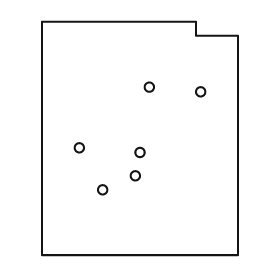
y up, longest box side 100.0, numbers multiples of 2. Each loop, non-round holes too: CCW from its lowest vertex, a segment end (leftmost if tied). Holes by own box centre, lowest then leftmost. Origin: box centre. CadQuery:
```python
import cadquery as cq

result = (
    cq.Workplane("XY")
    .moveTo(-42.0, -50.0)
    .lineTo(42.0, -50.0)
    .lineTo(42.0, 44.0)
    .lineTo(24.0, 44.0)
    .lineTo(24.0, 50.0)
    .lineTo(-42.0, 50.0)
    .close()
    .moveTo(-16.0, -22.0)
    .circle(2.0)
    .moveTo(-2.0, -16.0)
    .circle(2.0)
    .moveTo(0.0, -6.0)
    .circle(2.0)
    .moveTo(-26.0, -4.0)
    .circle(2.0)
    .moveTo(26.0, 20.0)
    .circle(2.0)
    .moveTo(4.0, 22.0)
    .circle(2.0)
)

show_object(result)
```